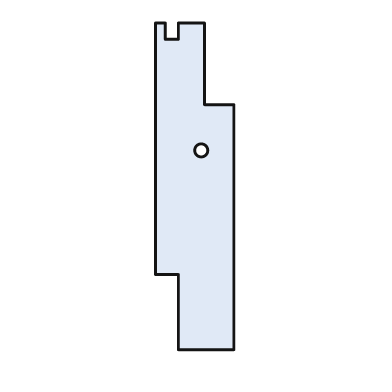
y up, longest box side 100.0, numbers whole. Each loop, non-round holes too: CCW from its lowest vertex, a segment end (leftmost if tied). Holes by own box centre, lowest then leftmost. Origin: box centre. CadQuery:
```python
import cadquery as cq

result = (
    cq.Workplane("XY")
    .moveTo(-5.0, -50.0)
    .lineTo(12.0, -50.0)
    .lineTo(12.0, 25.0)
    .lineTo(3.0, 25.0)
    .lineTo(3.0, 50.0)
    .lineTo(-5.0, 50.0)
    .lineTo(-5.0, 45.0)
    .lineTo(-9.0, 45.0)
    .lineTo(-9.0, 50.0)
    .lineTo(-12.0, 50.0)
    .lineTo(-12.0, -27.0)
    .lineTo(-5.0, -27.0)
    .close()
    .moveTo(2.0, 11.0)
    .circle(2.0)
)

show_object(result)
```